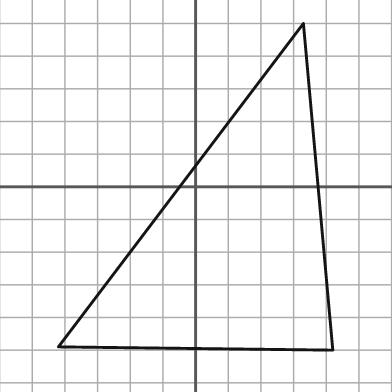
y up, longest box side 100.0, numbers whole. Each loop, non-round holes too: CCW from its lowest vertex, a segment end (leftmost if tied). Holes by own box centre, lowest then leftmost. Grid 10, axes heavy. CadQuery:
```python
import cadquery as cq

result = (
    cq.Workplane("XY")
    .moveTo(42.0, -50.0)
    .lineTo(33.0, 50.0)
    .lineTo(-42.0, -49.0)
    .close()
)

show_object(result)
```